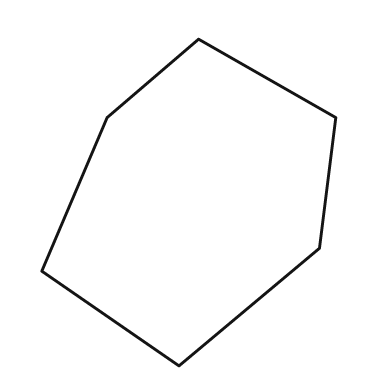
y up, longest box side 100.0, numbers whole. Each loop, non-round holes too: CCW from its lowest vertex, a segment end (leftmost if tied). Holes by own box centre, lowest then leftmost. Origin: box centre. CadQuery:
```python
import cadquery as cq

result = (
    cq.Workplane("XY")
    .moveTo(-3.0, -50.0)
    .lineTo(40.0, -14.0)
    .lineTo(45.0, 26.0)
    .lineTo(3.0, 50.0)
    .lineTo(-25.0, 26.0)
    .lineTo(-45.0, -21.0)
    .close()
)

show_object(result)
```